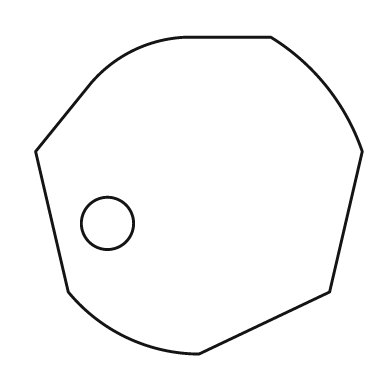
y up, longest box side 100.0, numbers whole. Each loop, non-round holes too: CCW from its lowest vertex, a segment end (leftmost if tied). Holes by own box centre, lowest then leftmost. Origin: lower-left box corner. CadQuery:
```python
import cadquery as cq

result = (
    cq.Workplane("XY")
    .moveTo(50.0, 0.0)
    .lineTo(90.0, 19.0)
    .lineTo(100.0, 62.0)
    .threePointArc((89.0, 82.0), (72.0, 97.0))
    .lineTo(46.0, 97.0)
    .threePointArc((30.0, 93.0), (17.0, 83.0))
    .lineTo(0.0, 62.0)
    .lineTo(10.0, 19.0)
    .threePointArc((28.0, 5.0), (50.0, 0.0))
    .close()
    .moveTo(22.0, 40.0)
    .circle(8.0)
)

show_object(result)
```